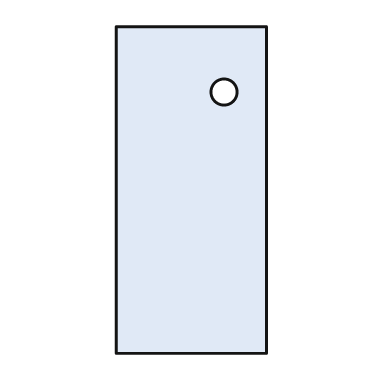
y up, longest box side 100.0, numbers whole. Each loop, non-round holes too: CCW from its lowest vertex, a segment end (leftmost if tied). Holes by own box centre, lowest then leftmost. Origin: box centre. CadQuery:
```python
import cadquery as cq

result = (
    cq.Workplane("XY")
    .moveTo(-23.0, -50.0)
    .lineTo(23.0, -50.0)
    .lineTo(23.0, 50.0)
    .lineTo(-23.0, 50.0)
    .close()
    .moveTo(10.0, 30.0)
    .circle(4.0)
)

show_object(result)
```